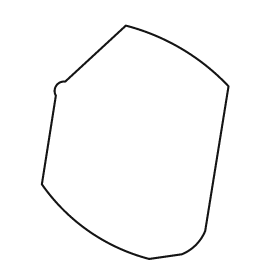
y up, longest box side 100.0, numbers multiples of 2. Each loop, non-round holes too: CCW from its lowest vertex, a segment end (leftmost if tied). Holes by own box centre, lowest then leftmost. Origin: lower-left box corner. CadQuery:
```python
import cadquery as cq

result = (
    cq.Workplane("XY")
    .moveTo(46.0, 0.0)
    .lineTo(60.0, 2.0)
    .threePointArc((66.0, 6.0), (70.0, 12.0))
    .lineTo(80.0, 74.0)
    .threePointArc((60.0, 90.0), (36.0, 100.0))
    .lineTo(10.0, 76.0)
    .threePointArc((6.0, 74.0), (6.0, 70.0))
    .lineTo(0.0, 32.0)
    .threePointArc((20.0, 12.0), (46.0, 0.0))
    .close()
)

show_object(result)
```